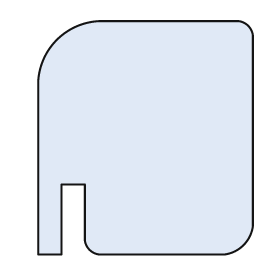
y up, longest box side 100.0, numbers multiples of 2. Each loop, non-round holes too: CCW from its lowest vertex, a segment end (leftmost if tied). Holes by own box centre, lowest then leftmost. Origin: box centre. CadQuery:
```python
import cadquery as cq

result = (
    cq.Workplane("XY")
    .moveTo(-46.0, -50.0)
    .lineTo(-36.0, -50.0)
    .lineTo(-36.0, -20.0)
    .lineTo(-26.0, -20.0)
    .lineTo(-26.0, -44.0)
    .threePointArc((-24.0, -48.0), (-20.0, -50.0))
    .lineTo(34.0, -50.0)
    .threePointArc((42.0, -46.0), (46.0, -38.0))
    .lineTo(46.0, 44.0)
    .threePointArc((44.0, 48.0), (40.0, 50.0))
    .lineTo(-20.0, 50.0)
    .threePointArc((-38.0, 42.0), (-46.0, 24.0))
    .close()
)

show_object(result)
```